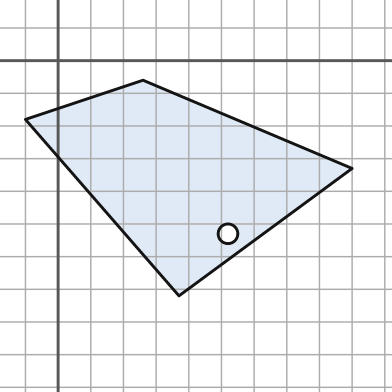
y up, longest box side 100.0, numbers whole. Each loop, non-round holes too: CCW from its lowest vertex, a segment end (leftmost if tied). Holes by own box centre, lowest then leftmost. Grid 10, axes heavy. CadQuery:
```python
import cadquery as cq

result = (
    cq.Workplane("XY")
    .moveTo(37.0, -72.0)
    .lineTo(90.0, -33.0)
    .lineTo(26.0, -6.0)
    .lineTo(-10.0, -18.0)
    .close()
    .moveTo(52.0, -53.0)
    .circle(3.0)
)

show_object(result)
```